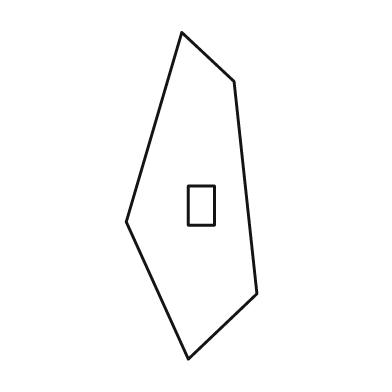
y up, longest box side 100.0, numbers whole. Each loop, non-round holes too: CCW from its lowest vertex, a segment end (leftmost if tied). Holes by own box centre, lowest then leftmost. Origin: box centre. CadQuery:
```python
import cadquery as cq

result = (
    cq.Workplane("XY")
    .moveTo(-1.0, -50.0)
    .lineTo(20.0, -30.0)
    .lineTo(13.0, 35.0)
    .lineTo(-3.0, 50.0)
    .lineTo(-20.0, -8.0)
    .close()
    .moveTo(-1.0, -9.0)
    .lineTo(7.0, -9.0)
    .lineTo(7.0, 3.0)
    .lineTo(-1.0, 3.0)
    .close()
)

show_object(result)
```